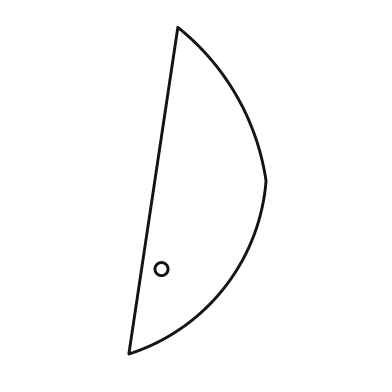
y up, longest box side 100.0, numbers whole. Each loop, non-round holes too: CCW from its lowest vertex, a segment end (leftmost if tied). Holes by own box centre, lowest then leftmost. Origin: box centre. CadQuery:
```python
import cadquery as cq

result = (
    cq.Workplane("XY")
    .moveTo(-21.0, -50.0)
    .threePointArc((8.0, -30.0), (21.0, 3.0))
    .threePointArc((12.0, 29.0), (-6.0, 50.0))
    .close()
    .moveTo(-11.0, -24.0)
    .circle(2.0)
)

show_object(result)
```